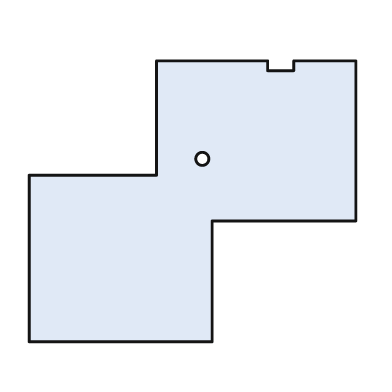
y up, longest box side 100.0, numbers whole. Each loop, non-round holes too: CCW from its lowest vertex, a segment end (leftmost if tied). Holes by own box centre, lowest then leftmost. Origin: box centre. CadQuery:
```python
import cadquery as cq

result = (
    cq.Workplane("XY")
    .moveTo(-50.0, -43.0)
    .lineTo(6.0, -43.0)
    .lineTo(6.0, -6.0)
    .lineTo(50.0, -6.0)
    .lineTo(50.0, 43.0)
    .lineTo(31.0, 43.0)
    .lineTo(31.0, 40.0)
    .lineTo(23.0, 40.0)
    .lineTo(23.0, 43.0)
    .lineTo(-11.0, 43.0)
    .lineTo(-11.0, 8.0)
    .lineTo(-50.0, 8.0)
    .close()
    .moveTo(3.0, 13.0)
    .circle(2.0)
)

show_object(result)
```